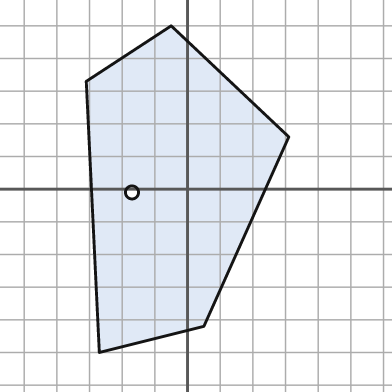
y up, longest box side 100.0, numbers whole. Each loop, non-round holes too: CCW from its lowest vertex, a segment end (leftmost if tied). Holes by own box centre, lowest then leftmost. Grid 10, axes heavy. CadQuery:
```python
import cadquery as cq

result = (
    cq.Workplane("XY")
    .moveTo(-27.0, -50.0)
    .lineTo(5.0, -42.0)
    .lineTo(31.0, 16.0)
    .lineTo(-5.0, 50.0)
    .lineTo(-31.0, 33.0)
    .close()
    .moveTo(-17.0, -1.0)
    .circle(2.0)
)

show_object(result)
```